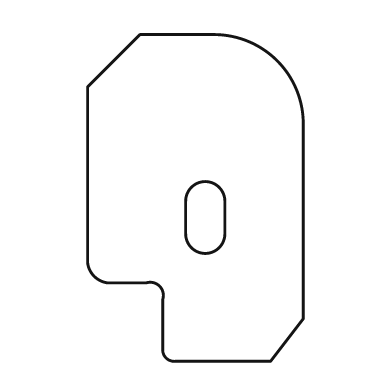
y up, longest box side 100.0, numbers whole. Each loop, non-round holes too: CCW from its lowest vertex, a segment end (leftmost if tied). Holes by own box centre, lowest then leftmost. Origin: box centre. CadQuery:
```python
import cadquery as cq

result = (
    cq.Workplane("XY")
    .moveTo(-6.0, -50.0)
    .lineTo(23.0, -50.0)
    .lineTo(33.0, -37.0)
    .lineTo(33.0, 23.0)
    .threePointArc((25.0, 42.0), (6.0, 50.0))
    .lineTo(-17.0, 50.0)
    .lineTo(-33.0, 34.0)
    .lineTo(-33.0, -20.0)
    .threePointArc((-31.0, -24.0), (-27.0, -26.0))
    .lineTo(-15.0, -26.0)
    .threePointArc((-11.0, -27.0), (-10.0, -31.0))
    .lineTo(-10.0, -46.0)
    .threePointArc((-9.0, -49.0), (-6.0, -50.0))
    .close()
    .moveTo(-3.0, -11.0)
    .threePointArc((3.0, -17.0), (9.0, -11.0))
    .lineTo(9.0, -1.0)
    .threePointArc((3.0, 5.0), (-3.0, -1.0))
    .close()
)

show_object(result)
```